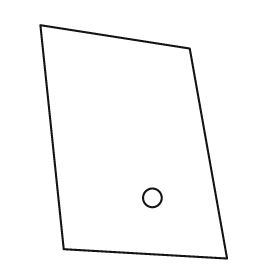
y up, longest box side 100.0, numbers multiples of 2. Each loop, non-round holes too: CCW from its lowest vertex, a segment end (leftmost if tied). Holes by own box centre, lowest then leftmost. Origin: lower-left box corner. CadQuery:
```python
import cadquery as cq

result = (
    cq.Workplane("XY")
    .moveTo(80.0, 0.0)
    .lineTo(64.0, 90.0)
    .lineTo(0.0, 100.0)
    .lineTo(10.0, 4.0)
    .close()
    .moveTo(48.0, 26.0)
    .circle(4.0)
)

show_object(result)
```